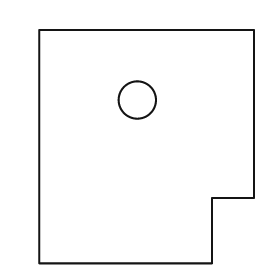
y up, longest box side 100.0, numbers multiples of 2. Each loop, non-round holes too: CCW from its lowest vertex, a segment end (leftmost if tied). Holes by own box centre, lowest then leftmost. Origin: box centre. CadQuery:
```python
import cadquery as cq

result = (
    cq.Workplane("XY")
    .moveTo(-46.0, -50.0)
    .lineTo(28.0, -50.0)
    .lineTo(28.0, -22.0)
    .lineTo(46.0, -22.0)
    .lineTo(46.0, 50.0)
    .lineTo(-46.0, 50.0)
    .close()
    .moveTo(-4.0, 20.0)
    .circle(8.0)
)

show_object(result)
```